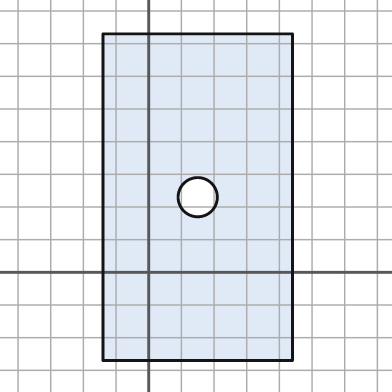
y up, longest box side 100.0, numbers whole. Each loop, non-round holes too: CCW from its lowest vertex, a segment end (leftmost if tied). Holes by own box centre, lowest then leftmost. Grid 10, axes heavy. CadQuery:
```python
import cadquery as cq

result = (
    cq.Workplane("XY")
    .moveTo(-14.0, -27.0)
    .lineTo(44.0, -27.0)
    .lineTo(44.0, 73.0)
    .lineTo(-14.0, 73.0)
    .close()
    .moveTo(15.0, 23.0)
    .circle(6.0)
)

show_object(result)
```